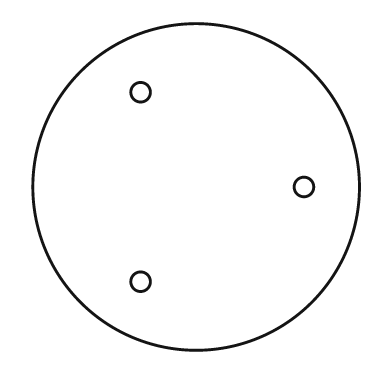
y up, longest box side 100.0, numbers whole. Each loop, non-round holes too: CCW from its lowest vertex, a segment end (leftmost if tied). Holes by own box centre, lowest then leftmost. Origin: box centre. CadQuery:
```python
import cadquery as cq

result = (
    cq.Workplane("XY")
    .moveTo(0.0, 0.0)
    .circle(50.0)
    .moveTo(-17.0, -29.0)
    .circle(3.0)
    .moveTo(33.0, 0.0)
    .circle(3.0)
    .moveTo(-17.0, 29.0)
    .circle(3.0)
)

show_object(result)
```